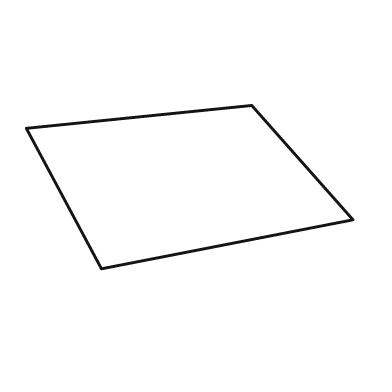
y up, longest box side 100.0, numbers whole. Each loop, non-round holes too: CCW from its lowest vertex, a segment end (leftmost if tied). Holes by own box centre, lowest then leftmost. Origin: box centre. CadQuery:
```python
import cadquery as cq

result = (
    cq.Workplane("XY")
    .moveTo(-27.0, -25.0)
    .lineTo(50.0, -10.0)
    .lineTo(19.0, 25.0)
    .lineTo(-50.0, 18.0)
    .close()
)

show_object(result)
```